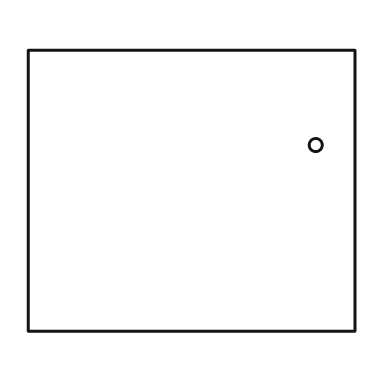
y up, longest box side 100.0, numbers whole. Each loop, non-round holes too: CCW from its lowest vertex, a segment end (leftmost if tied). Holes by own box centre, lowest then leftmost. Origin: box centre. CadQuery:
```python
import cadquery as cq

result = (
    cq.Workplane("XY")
    .moveTo(-50.0, -43.0)
    .lineTo(50.0, -43.0)
    .lineTo(50.0, 43.0)
    .lineTo(-50.0, 43.0)
    .close()
    .moveTo(38.0, 14.0)
    .circle(2.0)
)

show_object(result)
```